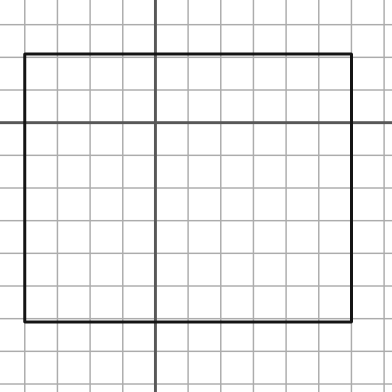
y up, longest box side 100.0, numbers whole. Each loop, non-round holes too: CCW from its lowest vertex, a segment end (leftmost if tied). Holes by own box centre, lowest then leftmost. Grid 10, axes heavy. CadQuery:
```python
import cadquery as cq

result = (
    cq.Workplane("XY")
    .moveTo(-40.0, -61.0)
    .lineTo(60.0, -61.0)
    .lineTo(60.0, 21.0)
    .lineTo(-40.0, 21.0)
    .close()
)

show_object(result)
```